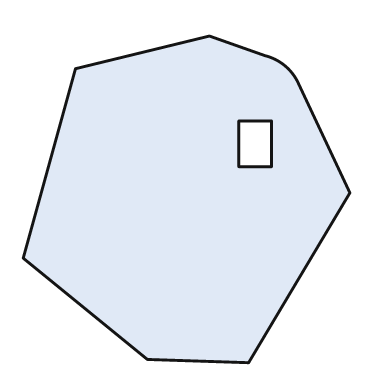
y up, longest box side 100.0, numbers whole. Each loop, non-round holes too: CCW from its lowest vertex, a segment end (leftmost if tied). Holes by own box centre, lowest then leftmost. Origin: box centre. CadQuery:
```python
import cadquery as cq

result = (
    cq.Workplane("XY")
    .moveTo(19.0, -50.0)
    .lineTo(50.0, 2.0)
    .lineTo(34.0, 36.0)
    .threePointArc((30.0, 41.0), (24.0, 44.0))
    .lineTo(7.0, 50.0)
    .lineTo(-34.0, 40.0)
    .lineTo(-50.0, -18.0)
    .lineTo(-12.0, -49.0)
    .close()
    .moveTo(16.0, 10.0)
    .lineTo(26.0, 10.0)
    .lineTo(26.0, 24.0)
    .lineTo(16.0, 24.0)
    .close()
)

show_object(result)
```